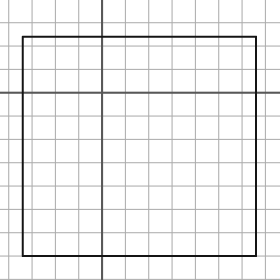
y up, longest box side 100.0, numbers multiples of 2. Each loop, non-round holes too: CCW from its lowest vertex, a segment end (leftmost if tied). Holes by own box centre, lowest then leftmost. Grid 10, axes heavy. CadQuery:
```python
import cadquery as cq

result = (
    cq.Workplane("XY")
    .moveTo(-34.0, -70.0)
    .lineTo(66.0, -70.0)
    .lineTo(66.0, 24.0)
    .lineTo(-34.0, 24.0)
    .close()
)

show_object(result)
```